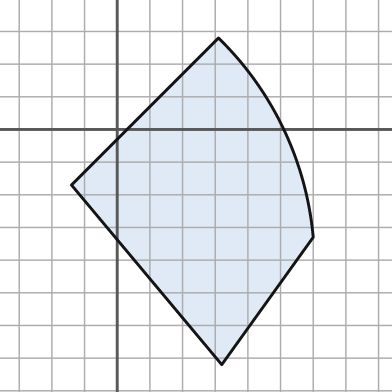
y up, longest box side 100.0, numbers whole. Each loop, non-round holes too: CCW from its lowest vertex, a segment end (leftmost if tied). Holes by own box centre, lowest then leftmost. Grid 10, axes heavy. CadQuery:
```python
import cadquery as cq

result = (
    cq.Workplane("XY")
    .moveTo(32.0, -72.0)
    .lineTo(60.0, -33.0)
    .threePointArc((51.0, 0.0), (31.0, 28.0))
    .lineTo(-14.0, -17.0)
    .close()
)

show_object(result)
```